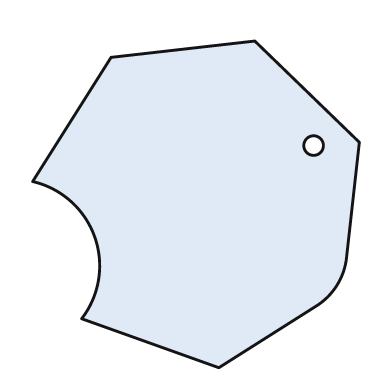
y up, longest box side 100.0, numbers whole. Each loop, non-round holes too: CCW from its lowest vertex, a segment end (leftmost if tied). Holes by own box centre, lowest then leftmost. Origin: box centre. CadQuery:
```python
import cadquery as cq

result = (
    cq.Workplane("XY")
    .moveTo(7.0, -50.0)
    .lineTo(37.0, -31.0)
    .threePointArc((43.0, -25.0), (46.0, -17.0))
    .lineTo(50.0, 19.0)
    .lineTo(18.0, 50.0)
    .lineTo(-26.0, 45.0)
    .lineTo(-50.0, 7.0)
    .threePointArc((-31.0, -10.0), (-35.0, -35.0))
    .close()
    .moveTo(36.0, 18.0)
    .circle(3.0)
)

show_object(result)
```